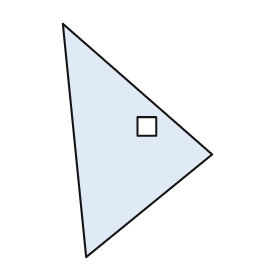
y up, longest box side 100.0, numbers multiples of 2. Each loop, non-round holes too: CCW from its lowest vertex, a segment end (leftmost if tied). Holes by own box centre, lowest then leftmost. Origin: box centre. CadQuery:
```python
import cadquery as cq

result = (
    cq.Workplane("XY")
    .moveTo(-22.0, -50.0)
    .lineTo(32.0, -6.0)
    .lineTo(-32.0, 50.0)
    .close()
    .moveTo(0.0, 2.0)
    .lineTo(8.0, 2.0)
    .lineTo(8.0, 10.0)
    .lineTo(0.0, 10.0)
    .close()
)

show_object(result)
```